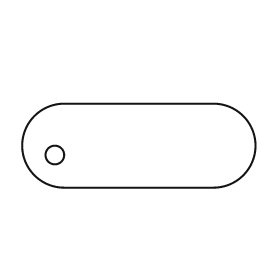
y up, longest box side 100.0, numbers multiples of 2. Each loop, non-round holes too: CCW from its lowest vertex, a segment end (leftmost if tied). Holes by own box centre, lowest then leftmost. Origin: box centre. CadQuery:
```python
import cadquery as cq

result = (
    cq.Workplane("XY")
    .moveTo(-32.0, -18.0)
    .lineTo(32.0, -18.0)
    .threePointArc((50.0, 0.0), (32.0, 18.0))
    .lineTo(-32.0, 18.0)
    .threePointArc((-50.0, 0.0), (-32.0, -18.0))
    .close()
    .moveTo(-36.0, -4.0)
    .circle(4.0)
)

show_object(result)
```